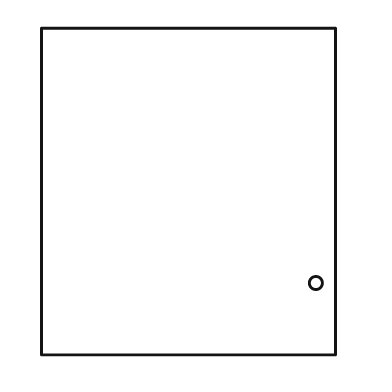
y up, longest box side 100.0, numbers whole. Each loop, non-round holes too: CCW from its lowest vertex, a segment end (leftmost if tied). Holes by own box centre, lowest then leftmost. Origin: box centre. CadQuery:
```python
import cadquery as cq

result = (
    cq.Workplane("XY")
    .moveTo(-45.0, -50.0)
    .lineTo(45.0, -50.0)
    .lineTo(45.0, 50.0)
    .lineTo(-45.0, 50.0)
    .close()
    .moveTo(39.0, -28.0)
    .circle(2.0)
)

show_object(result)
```